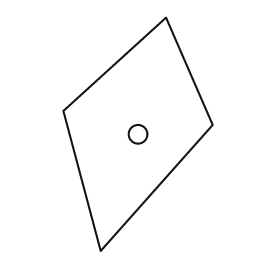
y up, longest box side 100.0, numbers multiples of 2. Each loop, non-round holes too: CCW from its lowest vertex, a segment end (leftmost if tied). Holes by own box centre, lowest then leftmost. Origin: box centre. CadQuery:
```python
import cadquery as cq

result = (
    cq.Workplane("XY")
    .moveTo(-16.0, -50.0)
    .lineTo(32.0, 4.0)
    .lineTo(12.0, 50.0)
    .lineTo(-32.0, 10.0)
    .close()
    .moveTo(0.0, 0.0)
    .circle(4.0)
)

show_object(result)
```